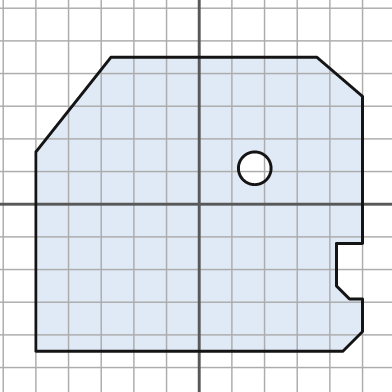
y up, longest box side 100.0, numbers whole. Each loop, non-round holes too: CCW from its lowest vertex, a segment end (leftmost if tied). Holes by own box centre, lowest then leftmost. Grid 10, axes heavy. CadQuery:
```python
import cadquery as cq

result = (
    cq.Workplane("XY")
    .moveTo(-50.0, -45.0)
    .lineTo(44.0, -45.0)
    .lineTo(50.0, -39.0)
    .lineTo(50.0, -29.0)
    .lineTo(46.0, -29.0)
    .lineTo(42.0, -25.0)
    .lineTo(42.0, -12.0)
    .lineTo(50.0, -12.0)
    .lineTo(50.0, 33.0)
    .lineTo(36.0, 45.0)
    .lineTo(-27.0, 45.0)
    .lineTo(-50.0, 16.0)
    .close()
    .moveTo(17.0, 11.0)
    .circle(5.0)
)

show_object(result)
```